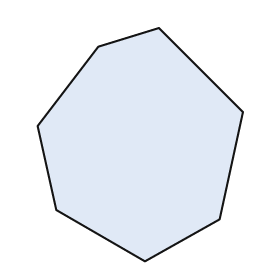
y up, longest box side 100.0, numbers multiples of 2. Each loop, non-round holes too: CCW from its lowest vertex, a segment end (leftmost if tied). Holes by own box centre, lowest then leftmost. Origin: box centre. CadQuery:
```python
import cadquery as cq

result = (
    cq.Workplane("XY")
    .moveTo(2.0, -50.0)
    .lineTo(34.0, -32.0)
    .lineTo(44.0, 14.0)
    .lineTo(8.0, 50.0)
    .lineTo(-18.0, 42.0)
    .lineTo(-44.0, 8.0)
    .lineTo(-36.0, -28.0)
    .close()
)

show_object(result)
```